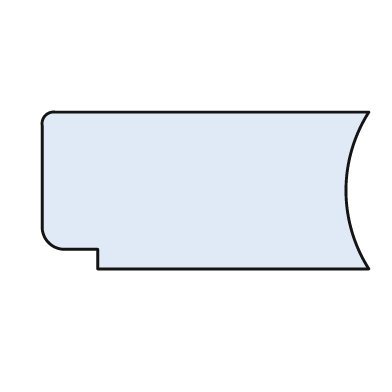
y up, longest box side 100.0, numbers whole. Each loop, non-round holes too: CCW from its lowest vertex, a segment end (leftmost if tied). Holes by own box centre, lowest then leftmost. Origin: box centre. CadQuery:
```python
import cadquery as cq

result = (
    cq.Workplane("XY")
    .moveTo(-33.0, -24.0)
    .lineTo(50.0, -24.0)
    .threePointArc((43.0, 0.0), (50.0, 24.0))
    .lineTo(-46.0, 24.0)
    .threePointArc((-49.0, 23.0), (-50.0, 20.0))
    .lineTo(-50.0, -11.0)
    .threePointArc((-48.0, -16.0), (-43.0, -18.0))
    .lineTo(-33.0, -18.0)
    .close()
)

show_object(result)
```